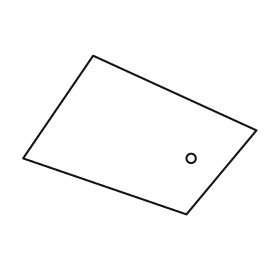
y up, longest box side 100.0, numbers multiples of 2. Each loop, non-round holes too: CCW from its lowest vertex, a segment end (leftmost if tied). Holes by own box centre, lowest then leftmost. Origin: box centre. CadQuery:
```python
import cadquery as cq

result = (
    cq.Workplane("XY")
    .moveTo(20.0, -34.0)
    .lineTo(50.0, 2.0)
    .lineTo(-20.0, 34.0)
    .lineTo(-50.0, -10.0)
    .close()
    .moveTo(22.0, -10.0)
    .circle(2.0)
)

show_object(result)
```